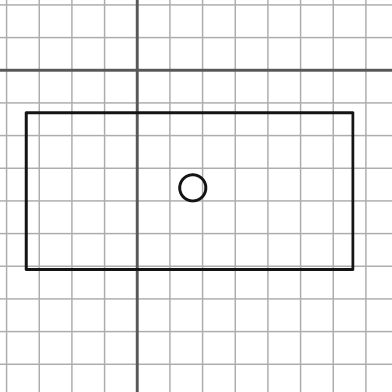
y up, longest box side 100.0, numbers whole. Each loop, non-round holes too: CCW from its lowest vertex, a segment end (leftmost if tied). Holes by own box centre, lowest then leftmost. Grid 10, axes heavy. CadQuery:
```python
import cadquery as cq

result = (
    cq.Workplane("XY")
    .moveTo(-34.0, -61.0)
    .lineTo(66.0, -61.0)
    .lineTo(66.0, -13.0)
    .lineTo(-34.0, -13.0)
    .close()
    .moveTo(17.0, -36.0)
    .circle(4.0)
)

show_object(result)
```